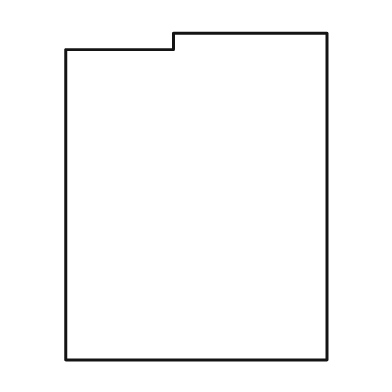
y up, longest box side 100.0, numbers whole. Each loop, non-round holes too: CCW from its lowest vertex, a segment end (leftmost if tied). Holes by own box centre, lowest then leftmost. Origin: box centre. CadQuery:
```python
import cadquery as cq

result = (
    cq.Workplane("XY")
    .moveTo(-40.0, -50.0)
    .lineTo(40.0, -50.0)
    .lineTo(40.0, 50.0)
    .lineTo(-7.0, 50.0)
    .lineTo(-7.0, 45.0)
    .lineTo(-40.0, 45.0)
    .close()
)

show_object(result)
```